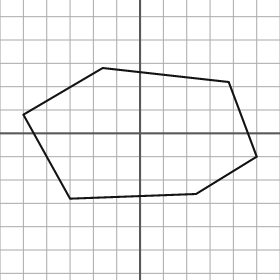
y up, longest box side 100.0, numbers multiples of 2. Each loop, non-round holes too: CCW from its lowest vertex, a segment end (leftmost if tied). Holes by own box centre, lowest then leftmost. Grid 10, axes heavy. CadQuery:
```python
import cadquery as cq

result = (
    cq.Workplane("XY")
    .moveTo(-30.0, -28.0)
    .lineTo(24.0, -26.0)
    .lineTo(50.0, -10.0)
    .lineTo(38.0, 22.0)
    .lineTo(-16.0, 28.0)
    .lineTo(-50.0, 8.0)
    .close()
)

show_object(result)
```